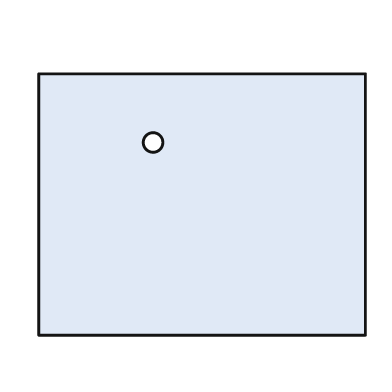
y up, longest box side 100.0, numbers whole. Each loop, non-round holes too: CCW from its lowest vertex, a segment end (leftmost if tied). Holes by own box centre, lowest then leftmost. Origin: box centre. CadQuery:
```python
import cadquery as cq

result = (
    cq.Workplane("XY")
    .moveTo(-50.0, -40.0)
    .lineTo(50.0, -40.0)
    .lineTo(50.0, 40.0)
    .lineTo(-50.0, 40.0)
    .close()
    .moveTo(-15.0, 19.0)
    .circle(3.0)
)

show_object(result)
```